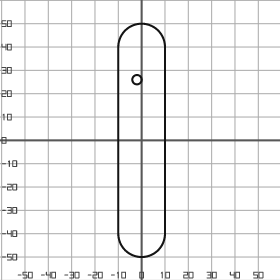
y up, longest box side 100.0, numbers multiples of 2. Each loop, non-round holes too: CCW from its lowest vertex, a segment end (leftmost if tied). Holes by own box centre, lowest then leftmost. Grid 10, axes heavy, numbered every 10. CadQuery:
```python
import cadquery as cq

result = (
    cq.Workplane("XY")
    .moveTo(-10.0, -40.0)
    .threePointArc((0.0, -50.0), (10.0, -40.0))
    .lineTo(10.0, 40.0)
    .threePointArc((0.0, 50.0), (-10.0, 40.0))
    .close()
    .moveTo(-2.0, 26.0)
    .circle(2.0)
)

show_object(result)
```